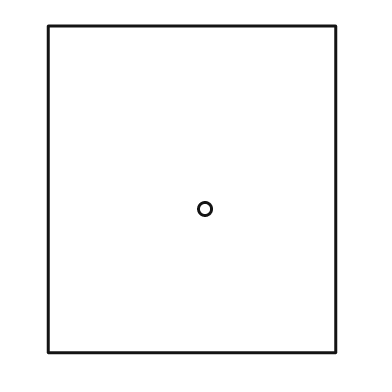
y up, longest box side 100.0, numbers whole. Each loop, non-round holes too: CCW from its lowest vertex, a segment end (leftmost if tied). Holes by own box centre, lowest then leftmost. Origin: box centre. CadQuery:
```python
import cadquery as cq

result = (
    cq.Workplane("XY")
    .moveTo(-44.0, -50.0)
    .lineTo(44.0, -50.0)
    .lineTo(44.0, 50.0)
    .lineTo(-44.0, 50.0)
    .close()
    .moveTo(4.0, -6.0)
    .circle(2.0)
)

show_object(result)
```